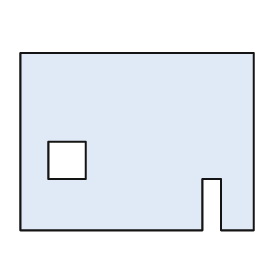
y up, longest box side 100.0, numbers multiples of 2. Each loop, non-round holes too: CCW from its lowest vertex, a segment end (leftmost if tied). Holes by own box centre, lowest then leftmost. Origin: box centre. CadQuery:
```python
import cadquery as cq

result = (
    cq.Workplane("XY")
    .moveTo(-50.0, -38.0)
    .lineTo(28.0, -38.0)
    .lineTo(28.0, -16.0)
    .lineTo(36.0, -16.0)
    .lineTo(36.0, -38.0)
    .lineTo(50.0, -38.0)
    .lineTo(50.0, 38.0)
    .lineTo(-50.0, 38.0)
    .close()
    .moveTo(-38.0, -16.0)
    .lineTo(-22.0, -16.0)
    .lineTo(-22.0, 0.0)
    .lineTo(-38.0, 0.0)
    .close()
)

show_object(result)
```